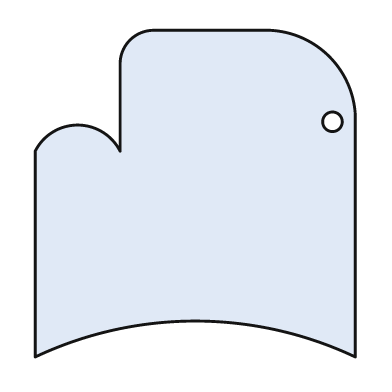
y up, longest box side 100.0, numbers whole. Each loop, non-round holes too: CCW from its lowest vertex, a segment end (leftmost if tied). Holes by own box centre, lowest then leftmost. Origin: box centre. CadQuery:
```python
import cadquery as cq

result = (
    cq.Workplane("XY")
    .moveTo(-49.0, -50.0)
    .threePointArc((0.0, -39.0), (49.0, -50.0))
    .lineTo(49.0, 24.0)
    .threePointArc((41.0, 42.0), (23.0, 50.0))
    .lineTo(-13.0, 50.0)
    .threePointArc((-20.0, 47.0), (-23.0, 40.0))
    .lineTo(-23.0, 13.0)
    .threePointArc((-36.0, 21.0), (-49.0, 13.0))
    .close()
    .moveTo(42.0, 22.0)
    .circle(3.0)
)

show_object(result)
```